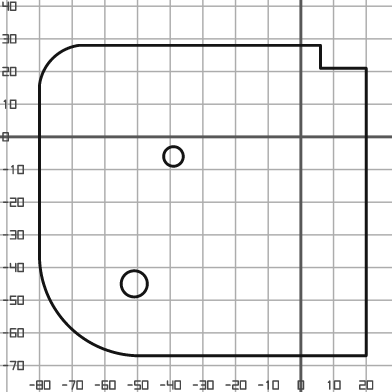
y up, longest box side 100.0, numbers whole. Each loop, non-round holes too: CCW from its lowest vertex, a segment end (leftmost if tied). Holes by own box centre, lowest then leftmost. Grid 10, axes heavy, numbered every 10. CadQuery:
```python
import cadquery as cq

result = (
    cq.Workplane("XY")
    .moveTo(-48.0, -67.0)
    .lineTo(20.0, -67.0)
    .lineTo(20.0, 21.0)
    .lineTo(6.0, 21.0)
    .lineTo(6.0, 28.0)
    .lineTo(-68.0, 28.0)
    .threePointArc((-76.0, 24.0), (-80.0, 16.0))
    .lineTo(-80.0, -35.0)
    .threePointArc((-71.0, -58.0), (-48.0, -67.0))
    .close()
    .moveTo(-51.0, -45.0)
    .circle(4.0)
    .moveTo(-39.0, -6.0)
    .circle(3.0)
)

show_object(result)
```